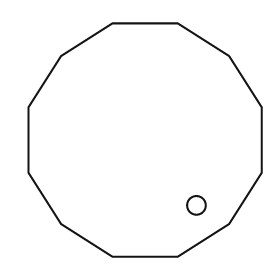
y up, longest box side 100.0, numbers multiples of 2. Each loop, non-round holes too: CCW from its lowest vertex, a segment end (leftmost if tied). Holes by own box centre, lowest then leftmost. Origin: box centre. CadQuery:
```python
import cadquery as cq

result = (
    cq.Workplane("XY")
    .moveTo(-14.0, -50.0)
    .lineTo(14.0, -50.0)
    .lineTo(36.0, -36.0)
    .lineTo(50.0, -14.0)
    .lineTo(50.0, 14.0)
    .lineTo(36.0, 36.0)
    .lineTo(14.0, 50.0)
    .lineTo(-14.0, 50.0)
    .lineTo(-36.0, 36.0)
    .lineTo(-50.0, 14.0)
    .lineTo(-50.0, -14.0)
    .lineTo(-36.0, -36.0)
    .close()
    .moveTo(22.0, -28.0)
    .circle(4.0)
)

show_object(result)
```